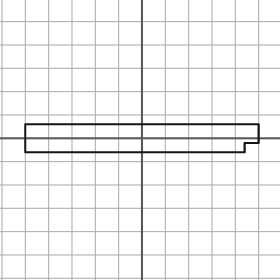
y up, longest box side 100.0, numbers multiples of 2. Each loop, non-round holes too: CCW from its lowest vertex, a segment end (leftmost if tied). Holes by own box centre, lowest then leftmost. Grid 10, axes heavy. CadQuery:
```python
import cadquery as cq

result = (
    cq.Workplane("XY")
    .moveTo(-50.0, -6.0)
    .lineTo(44.0, -6.0)
    .lineTo(44.0, -2.0)
    .lineTo(50.0, -2.0)
    .lineTo(50.0, 6.0)
    .lineTo(-50.0, 6.0)
    .close()
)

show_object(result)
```